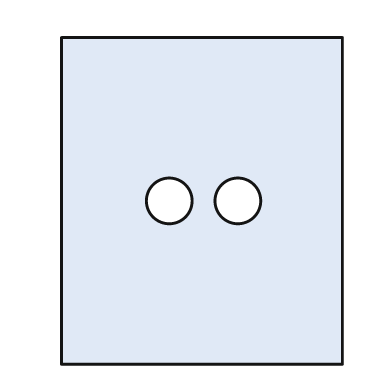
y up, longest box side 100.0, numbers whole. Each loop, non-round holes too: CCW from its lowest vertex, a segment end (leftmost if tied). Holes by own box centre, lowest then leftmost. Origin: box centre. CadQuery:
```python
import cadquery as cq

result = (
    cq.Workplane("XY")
    .moveTo(-43.0, -50.0)
    .lineTo(43.0, -50.0)
    .lineTo(43.0, 50.0)
    .lineTo(-43.0, 50.0)
    .close()
    .moveTo(-10.0, 0.0)
    .circle(7.0)
    .moveTo(11.0, 0.0)
    .circle(7.0)
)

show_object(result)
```